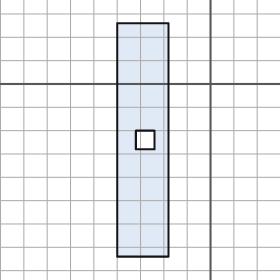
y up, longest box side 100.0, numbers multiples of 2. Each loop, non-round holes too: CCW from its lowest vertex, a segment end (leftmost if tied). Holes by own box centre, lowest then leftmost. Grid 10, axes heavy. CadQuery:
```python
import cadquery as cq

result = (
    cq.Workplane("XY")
    .moveTo(-40.0, -74.0)
    .lineTo(-18.0, -74.0)
    .lineTo(-18.0, 26.0)
    .lineTo(-40.0, 26.0)
    .close()
    .moveTo(-32.0, -28.0)
    .lineTo(-24.0, -28.0)
    .lineTo(-24.0, -20.0)
    .lineTo(-32.0, -20.0)
    .close()
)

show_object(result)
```